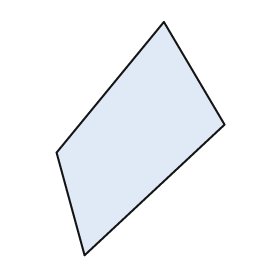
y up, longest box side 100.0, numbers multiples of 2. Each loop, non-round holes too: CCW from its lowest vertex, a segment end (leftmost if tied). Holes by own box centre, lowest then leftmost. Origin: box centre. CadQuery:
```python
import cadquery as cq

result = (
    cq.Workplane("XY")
    .moveTo(-24.0, -50.0)
    .lineTo(36.0, 6.0)
    .lineTo(10.0, 50.0)
    .lineTo(-36.0, -6.0)
    .close()
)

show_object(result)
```